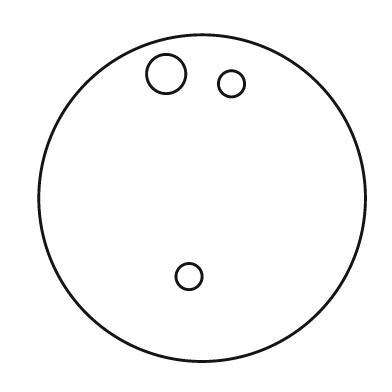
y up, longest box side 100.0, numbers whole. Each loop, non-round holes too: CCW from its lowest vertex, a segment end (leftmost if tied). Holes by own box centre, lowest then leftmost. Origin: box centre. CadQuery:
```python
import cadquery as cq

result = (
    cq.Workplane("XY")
    .moveTo(0.0, 0.0)
    .circle(50.0)
    .moveTo(-4.0, -24.0)
    .circle(4.0)
    .moveTo(9.0, 35.0)
    .circle(4.0)
    .moveTo(-11.0, 38.0)
    .circle(6.0)
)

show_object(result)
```